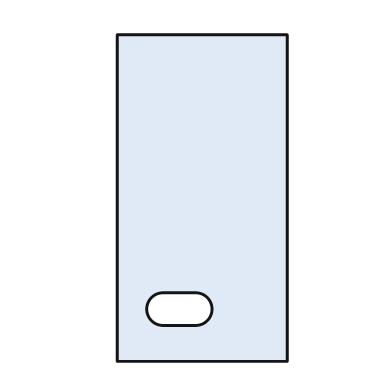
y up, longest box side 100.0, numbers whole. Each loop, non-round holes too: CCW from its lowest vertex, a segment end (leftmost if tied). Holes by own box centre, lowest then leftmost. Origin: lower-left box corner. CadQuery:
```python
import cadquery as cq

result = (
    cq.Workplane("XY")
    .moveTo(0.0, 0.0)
    .lineTo(52.0, 0.0)
    .lineTo(52.0, 100.0)
    .lineTo(0.0, 100.0)
    .close()
    .moveTo(14.0, 11.0)
    .lineTo(24.0, 11.0)
    .threePointArc((29.0, 16.0), (24.0, 21.0))
    .lineTo(14.0, 21.0)
    .threePointArc((9.0, 16.0), (14.0, 11.0))
    .close()
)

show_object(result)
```